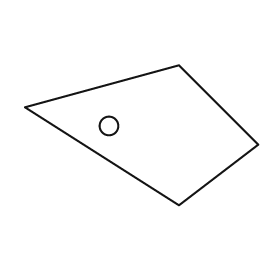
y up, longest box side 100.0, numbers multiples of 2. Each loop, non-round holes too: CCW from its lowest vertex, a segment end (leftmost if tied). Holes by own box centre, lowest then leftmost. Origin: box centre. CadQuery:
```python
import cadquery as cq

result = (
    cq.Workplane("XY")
    .moveTo(16.0, -30.0)
    .lineTo(50.0, -4.0)
    .lineTo(16.0, 30.0)
    .lineTo(-50.0, 12.0)
    .close()
    .moveTo(-14.0, 4.0)
    .circle(4.0)
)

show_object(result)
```